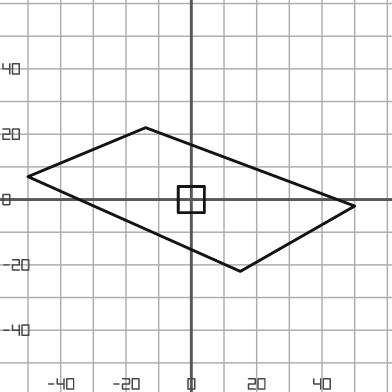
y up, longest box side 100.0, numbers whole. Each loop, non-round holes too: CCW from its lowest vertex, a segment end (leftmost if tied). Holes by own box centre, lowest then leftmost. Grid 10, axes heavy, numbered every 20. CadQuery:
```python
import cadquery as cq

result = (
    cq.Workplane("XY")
    .moveTo(15.0, -22.0)
    .lineTo(50.0, -2.0)
    .lineTo(-14.0, 22.0)
    .lineTo(-50.0, 7.0)
    .close()
    .moveTo(-4.0, -4.0)
    .lineTo(4.0, -4.0)
    .lineTo(4.0, 4.0)
    .lineTo(-4.0, 4.0)
    .close()
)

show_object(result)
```